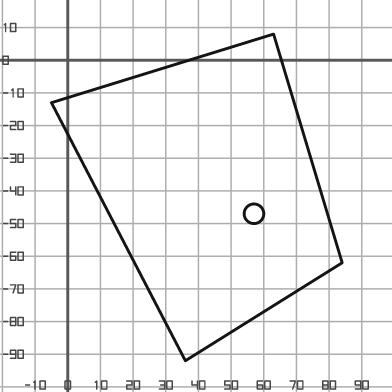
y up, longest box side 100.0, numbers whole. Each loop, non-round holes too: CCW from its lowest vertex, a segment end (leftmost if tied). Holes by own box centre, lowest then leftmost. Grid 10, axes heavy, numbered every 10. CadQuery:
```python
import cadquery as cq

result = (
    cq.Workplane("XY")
    .moveTo(36.0, -92.0)
    .lineTo(84.0, -62.0)
    .lineTo(63.0, 8.0)
    .lineTo(-5.0, -13.0)
    .close()
    .moveTo(57.0, -47.0)
    .circle(3.0)
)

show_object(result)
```